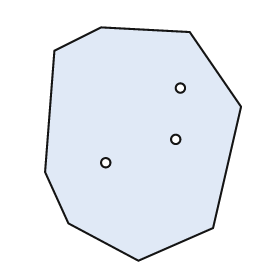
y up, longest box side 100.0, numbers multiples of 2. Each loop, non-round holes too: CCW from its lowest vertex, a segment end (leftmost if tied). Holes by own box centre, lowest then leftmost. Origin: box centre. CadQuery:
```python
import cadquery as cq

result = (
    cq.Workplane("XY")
    .moveTo(-2.0, -50.0)
    .lineTo(30.0, -36.0)
    .lineTo(42.0, 16.0)
    .lineTo(20.0, 48.0)
    .lineTo(-18.0, 50.0)
    .lineTo(-38.0, 40.0)
    .lineTo(-42.0, -12.0)
    .lineTo(-32.0, -34.0)
    .close()
    .moveTo(-16.0, -8.0)
    .circle(2.0)
    .moveTo(14.0, 2.0)
    .circle(2.0)
    .moveTo(16.0, 24.0)
    .circle(2.0)
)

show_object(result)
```